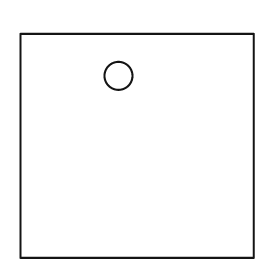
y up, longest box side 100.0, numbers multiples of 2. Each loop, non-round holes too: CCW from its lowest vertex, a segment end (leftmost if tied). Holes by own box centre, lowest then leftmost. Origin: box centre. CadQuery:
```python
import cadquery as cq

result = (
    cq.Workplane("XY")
    .moveTo(-50.0, -48.0)
    .lineTo(50.0, -48.0)
    .lineTo(50.0, 48.0)
    .lineTo(-50.0, 48.0)
    .close()
    .moveTo(-8.0, 30.0)
    .circle(6.0)
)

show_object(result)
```